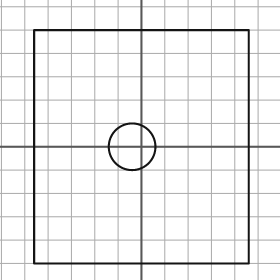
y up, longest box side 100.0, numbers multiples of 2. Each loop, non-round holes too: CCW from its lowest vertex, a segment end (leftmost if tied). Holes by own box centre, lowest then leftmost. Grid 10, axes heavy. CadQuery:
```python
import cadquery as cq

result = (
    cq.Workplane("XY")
    .moveTo(-46.0, -50.0)
    .lineTo(46.0, -50.0)
    .lineTo(46.0, 50.0)
    .lineTo(-46.0, 50.0)
    .close()
    .moveTo(-4.0, 0.0)
    .circle(10.0)
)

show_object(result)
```